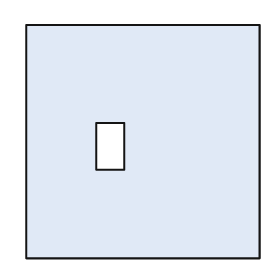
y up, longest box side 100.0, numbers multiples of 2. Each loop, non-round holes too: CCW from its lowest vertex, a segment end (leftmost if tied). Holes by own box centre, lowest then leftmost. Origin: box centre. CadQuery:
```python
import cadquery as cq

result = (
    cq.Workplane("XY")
    .moveTo(-50.0, -50.0)
    .lineTo(50.0, -50.0)
    .lineTo(50.0, 50.0)
    .lineTo(-50.0, 50.0)
    .close()
    .moveTo(-20.0, -12.0)
    .lineTo(-8.0, -12.0)
    .lineTo(-8.0, 8.0)
    .lineTo(-20.0, 8.0)
    .close()
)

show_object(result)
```